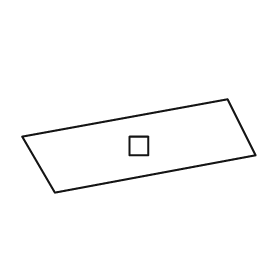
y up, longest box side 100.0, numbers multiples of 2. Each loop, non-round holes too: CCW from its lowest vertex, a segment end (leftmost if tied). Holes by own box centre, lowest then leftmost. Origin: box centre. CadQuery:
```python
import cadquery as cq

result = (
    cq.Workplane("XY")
    .moveTo(-36.0, -20.0)
    .lineTo(50.0, -4.0)
    .lineTo(38.0, 20.0)
    .lineTo(-50.0, 4.0)
    .close()
    .moveTo(-4.0, -4.0)
    .lineTo(4.0, -4.0)
    .lineTo(4.0, 4.0)
    .lineTo(-4.0, 4.0)
    .close()
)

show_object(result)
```